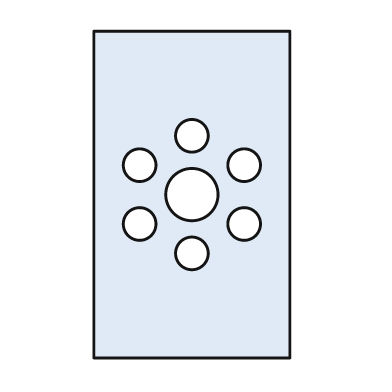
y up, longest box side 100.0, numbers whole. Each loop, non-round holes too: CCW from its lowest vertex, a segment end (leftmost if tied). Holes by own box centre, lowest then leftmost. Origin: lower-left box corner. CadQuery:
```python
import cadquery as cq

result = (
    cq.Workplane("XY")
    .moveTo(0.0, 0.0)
    .lineTo(60.0, 0.0)
    .lineTo(60.0, 100.0)
    .lineTo(0.0, 100.0)
    .close()
    .moveTo(30.0, 32.0)
    .circle(5.0)
    .moveTo(14.0, 41.0)
    .circle(5.0)
    .moveTo(46.0, 41.0)
    .circle(5.0)
    .moveTo(30.0, 50.0)
    .circle(8.0)
    .moveTo(14.0, 59.0)
    .circle(5.0)
    .moveTo(46.0, 59.0)
    .circle(5.0)
    .moveTo(30.0, 68.0)
    .circle(5.0)
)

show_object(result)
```